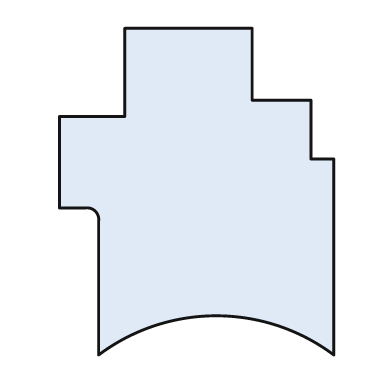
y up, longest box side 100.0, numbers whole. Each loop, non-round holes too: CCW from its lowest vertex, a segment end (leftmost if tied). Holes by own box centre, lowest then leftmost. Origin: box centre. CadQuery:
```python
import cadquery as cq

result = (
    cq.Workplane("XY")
    .moveTo(-30.0, -50.0)
    .threePointArc((6.0, -38.0), (42.0, -50.0))
    .lineTo(42.0, 10.0)
    .lineTo(35.0, 10.0)
    .lineTo(35.0, 28.0)
    .lineTo(17.0, 28.0)
    .lineTo(17.0, 50.0)
    .lineTo(-22.0, 50.0)
    .lineTo(-22.0, 23.0)
    .lineTo(-42.0, 23.0)
    .lineTo(-42.0, -5.0)
    .lineTo(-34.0, -5.0)
    .threePointArc((-31.0, -6.0), (-30.0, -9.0))
    .close()
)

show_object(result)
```